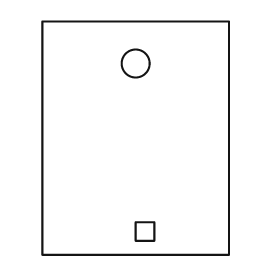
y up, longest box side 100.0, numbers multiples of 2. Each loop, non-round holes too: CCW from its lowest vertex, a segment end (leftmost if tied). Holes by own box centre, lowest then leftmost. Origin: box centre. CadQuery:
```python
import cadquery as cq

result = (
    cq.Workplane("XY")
    .moveTo(-40.0, -50.0)
    .lineTo(40.0, -50.0)
    .lineTo(40.0, 50.0)
    .lineTo(-40.0, 50.0)
    .close()
    .moveTo(0.0, -44.0)
    .lineTo(8.0, -44.0)
    .lineTo(8.0, -36.0)
    .lineTo(0.0, -36.0)
    .close()
    .moveTo(0.0, 32.0)
    .circle(6.0)
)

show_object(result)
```